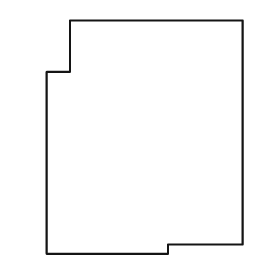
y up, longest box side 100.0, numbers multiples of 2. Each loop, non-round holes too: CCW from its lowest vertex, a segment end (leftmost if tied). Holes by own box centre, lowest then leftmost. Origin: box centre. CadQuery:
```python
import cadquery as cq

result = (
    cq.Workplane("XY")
    .moveTo(-42.0, -50.0)
    .lineTo(10.0, -50.0)
    .lineTo(10.0, -46.0)
    .lineTo(42.0, -46.0)
    .lineTo(42.0, 50.0)
    .lineTo(-32.0, 50.0)
    .lineTo(-32.0, 28.0)
    .lineTo(-42.0, 28.0)
    .close()
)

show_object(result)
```